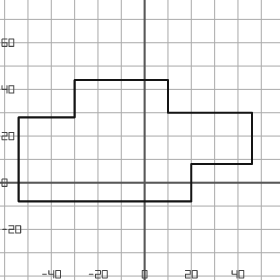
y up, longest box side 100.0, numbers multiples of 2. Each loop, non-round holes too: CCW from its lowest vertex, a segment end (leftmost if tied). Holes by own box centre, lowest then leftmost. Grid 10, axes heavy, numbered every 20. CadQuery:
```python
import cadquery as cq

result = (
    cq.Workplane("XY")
    .moveTo(-54.0, -8.0)
    .lineTo(20.0, -8.0)
    .lineTo(20.0, 8.0)
    .lineTo(46.0, 8.0)
    .lineTo(46.0, 30.0)
    .lineTo(10.0, 30.0)
    .lineTo(10.0, 44.0)
    .lineTo(-30.0, 44.0)
    .lineTo(-30.0, 28.0)
    .lineTo(-54.0, 28.0)
    .close()
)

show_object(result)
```